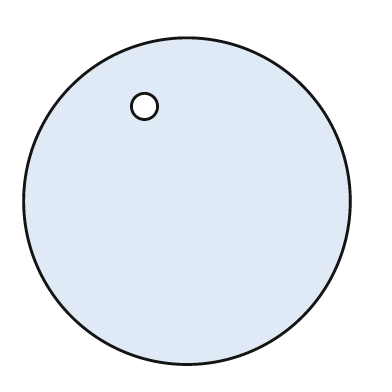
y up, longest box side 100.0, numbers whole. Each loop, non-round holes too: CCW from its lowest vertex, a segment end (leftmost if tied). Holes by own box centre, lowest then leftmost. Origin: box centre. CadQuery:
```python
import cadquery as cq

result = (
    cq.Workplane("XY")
    .moveTo(0.0, 0.0)
    .circle(50.0)
    .moveTo(-13.0, 29.0)
    .circle(4.0)
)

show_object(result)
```